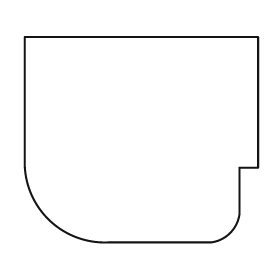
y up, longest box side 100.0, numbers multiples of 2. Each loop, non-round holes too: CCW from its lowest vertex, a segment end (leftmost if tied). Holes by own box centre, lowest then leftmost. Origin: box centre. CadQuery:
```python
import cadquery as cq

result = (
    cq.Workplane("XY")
    .moveTo(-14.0, -44.0)
    .lineTo(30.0, -44.0)
    .threePointArc((38.0, -40.0), (42.0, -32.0))
    .lineTo(42.0, -12.0)
    .lineTo(50.0, -12.0)
    .lineTo(50.0, 44.0)
    .lineTo(-50.0, 44.0)
    .lineTo(-50.0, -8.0)
    .threePointArc((-40.0, -34.0), (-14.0, -44.0))
    .close()
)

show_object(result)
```